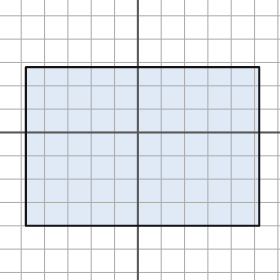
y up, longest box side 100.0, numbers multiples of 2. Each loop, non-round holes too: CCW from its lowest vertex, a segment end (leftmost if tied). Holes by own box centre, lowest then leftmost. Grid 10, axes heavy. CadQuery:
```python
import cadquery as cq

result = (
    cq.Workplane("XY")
    .moveTo(-48.0, -40.0)
    .lineTo(52.0, -40.0)
    .lineTo(52.0, 28.0)
    .lineTo(-48.0, 28.0)
    .close()
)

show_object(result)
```